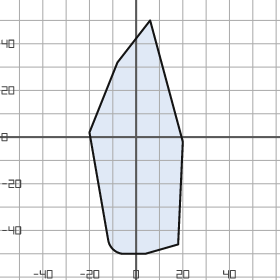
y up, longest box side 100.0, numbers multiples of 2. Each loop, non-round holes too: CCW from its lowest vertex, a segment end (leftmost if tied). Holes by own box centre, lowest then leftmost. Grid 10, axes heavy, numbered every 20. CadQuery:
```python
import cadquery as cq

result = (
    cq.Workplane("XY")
    .moveTo(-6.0, -50.0)
    .lineTo(4.0, -50.0)
    .lineTo(18.0, -46.0)
    .lineTo(20.0, -2.0)
    .lineTo(6.0, 50.0)
    .lineTo(-8.0, 32.0)
    .lineTo(-20.0, 2.0)
    .lineTo(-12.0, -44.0)
    .threePointArc((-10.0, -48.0), (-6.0, -50.0))
    .close()
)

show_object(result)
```